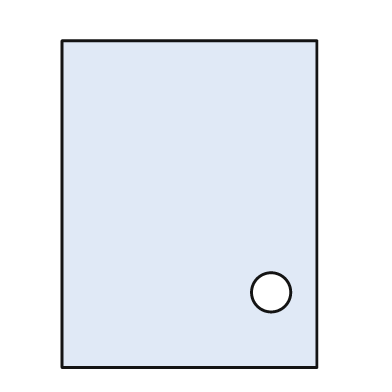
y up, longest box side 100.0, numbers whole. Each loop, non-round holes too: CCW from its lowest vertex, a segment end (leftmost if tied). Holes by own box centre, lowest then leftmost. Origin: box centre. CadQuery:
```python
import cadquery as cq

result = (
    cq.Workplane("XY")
    .moveTo(-39.0, -50.0)
    .lineTo(39.0, -50.0)
    .lineTo(39.0, 50.0)
    .lineTo(-39.0, 50.0)
    .close()
    .moveTo(25.0, -27.0)
    .circle(6.0)
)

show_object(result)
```